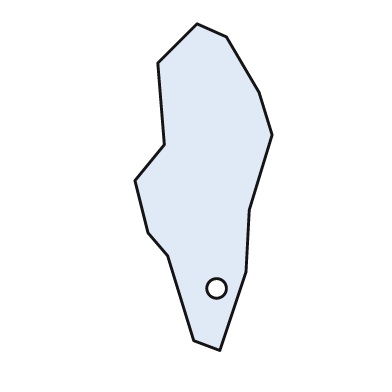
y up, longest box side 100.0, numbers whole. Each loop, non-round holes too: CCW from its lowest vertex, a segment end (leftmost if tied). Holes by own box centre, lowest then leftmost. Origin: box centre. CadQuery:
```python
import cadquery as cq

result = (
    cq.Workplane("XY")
    .moveTo(5.0, -50.0)
    .lineTo(13.0, -26.0)
    .lineTo(14.0, -7.0)
    .lineTo(21.0, 16.0)
    .lineTo(17.0, 29.0)
    .lineTo(7.0, 46.0)
    .lineTo(-2.0, 50.0)
    .lineTo(-14.0, 38.0)
    .lineTo(-12.0, 13.0)
    .lineTo(-21.0, 2.0)
    .lineTo(-17.0, -14.0)
    .lineTo(-11.0, -21.0)
    .lineTo(-3.0, -47.0)
    .close()
    .moveTo(4.0, -31.0)
    .circle(3.0)
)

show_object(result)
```